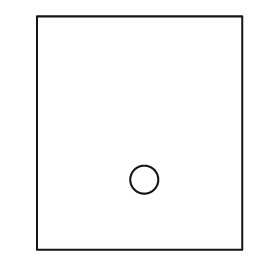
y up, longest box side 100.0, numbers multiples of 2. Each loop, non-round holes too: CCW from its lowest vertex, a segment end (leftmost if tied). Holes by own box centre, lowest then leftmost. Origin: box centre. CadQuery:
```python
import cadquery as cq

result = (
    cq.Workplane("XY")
    .moveTo(-44.0, -50.0)
    .lineTo(44.0, -50.0)
    .lineTo(44.0, 50.0)
    .lineTo(-44.0, 50.0)
    .close()
    .moveTo(2.0, -20.0)
    .circle(6.0)
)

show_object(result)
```